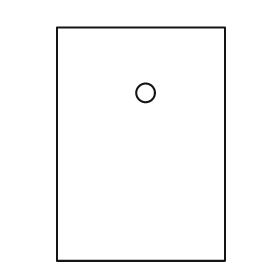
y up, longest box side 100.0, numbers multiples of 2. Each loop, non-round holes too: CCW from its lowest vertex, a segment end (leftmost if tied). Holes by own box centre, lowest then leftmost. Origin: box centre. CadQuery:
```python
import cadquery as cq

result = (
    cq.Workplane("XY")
    .moveTo(-36.0, -50.0)
    .lineTo(36.0, -50.0)
    .lineTo(36.0, 50.0)
    .lineTo(-36.0, 50.0)
    .close()
    .moveTo(2.0, 22.0)
    .circle(4.0)
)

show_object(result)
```